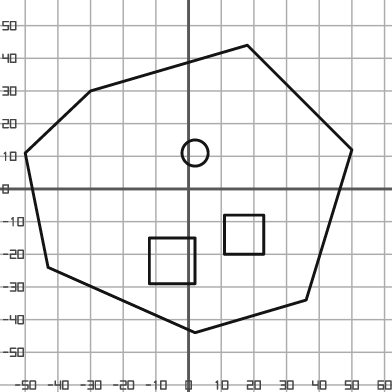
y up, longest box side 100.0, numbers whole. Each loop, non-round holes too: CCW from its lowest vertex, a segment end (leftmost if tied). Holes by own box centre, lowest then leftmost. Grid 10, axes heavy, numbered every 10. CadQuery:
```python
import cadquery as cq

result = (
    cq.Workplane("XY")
    .moveTo(2.0, -44.0)
    .lineTo(36.0, -34.0)
    .lineTo(50.0, 12.0)
    .lineTo(18.0, 44.0)
    .lineTo(-30.0, 30.0)
    .lineTo(-50.0, 11.0)
    .lineTo(-43.0, -24.0)
    .close()
    .moveTo(-12.0, -29.0)
    .lineTo(2.0, -29.0)
    .lineTo(2.0, -15.0)
    .lineTo(-12.0, -15.0)
    .close()
    .moveTo(11.0, -20.0)
    .lineTo(23.0, -20.0)
    .lineTo(23.0, -8.0)
    .lineTo(11.0, -8.0)
    .close()
    .moveTo(2.0, 11.0)
    .circle(4.0)
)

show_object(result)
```